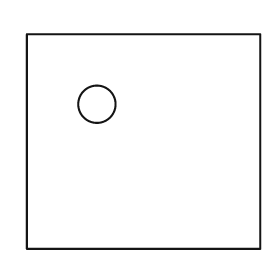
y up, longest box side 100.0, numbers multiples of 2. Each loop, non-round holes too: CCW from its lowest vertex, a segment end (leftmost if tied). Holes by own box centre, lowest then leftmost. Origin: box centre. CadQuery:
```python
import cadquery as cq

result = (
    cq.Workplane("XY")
    .moveTo(-50.0, -46.0)
    .lineTo(50.0, -46.0)
    .lineTo(50.0, 46.0)
    .lineTo(-50.0, 46.0)
    .close()
    .moveTo(-20.0, 16.0)
    .circle(8.0)
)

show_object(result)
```